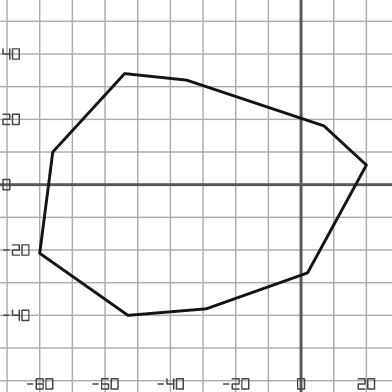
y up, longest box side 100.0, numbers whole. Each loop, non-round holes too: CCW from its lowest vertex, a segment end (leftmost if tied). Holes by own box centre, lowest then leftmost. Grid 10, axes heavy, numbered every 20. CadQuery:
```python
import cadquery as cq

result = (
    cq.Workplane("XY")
    .moveTo(-53.0, -40.0)
    .lineTo(-29.0, -38.0)
    .lineTo(2.0, -27.0)
    .lineTo(20.0, 6.0)
    .lineTo(7.0, 18.0)
    .lineTo(-35.0, 32.0)
    .lineTo(-54.0, 34.0)
    .lineTo(-76.0, 10.0)
    .lineTo(-80.0, -21.0)
    .close()
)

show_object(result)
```